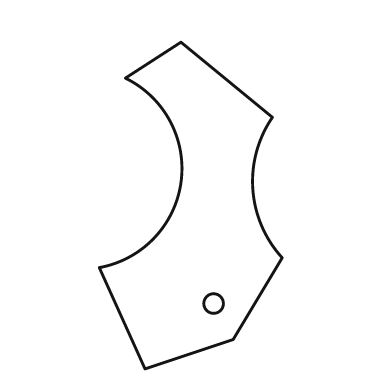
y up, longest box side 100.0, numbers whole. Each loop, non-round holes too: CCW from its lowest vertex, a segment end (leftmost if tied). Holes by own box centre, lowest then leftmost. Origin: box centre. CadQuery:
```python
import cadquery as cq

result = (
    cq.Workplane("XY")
    .moveTo(-14.0, -50.0)
    .lineTo(13.0, -41.0)
    .lineTo(28.0, -16.0)
    .threePointArc((19.0, 5.0), (25.0, 27.0))
    .lineTo(-3.0, 50.0)
    .lineTo(-20.0, 39.0)
    .threePointArc((-3.0, 7.0), (-28.0, -19.0))
    .close()
    .moveTo(7.0, -30.0)
    .circle(3.0)
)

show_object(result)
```